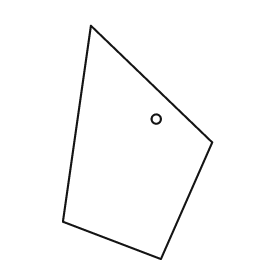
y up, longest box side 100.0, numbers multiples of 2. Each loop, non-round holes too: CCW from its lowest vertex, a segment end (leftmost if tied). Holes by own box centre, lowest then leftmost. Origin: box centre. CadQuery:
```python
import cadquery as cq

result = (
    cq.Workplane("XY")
    .moveTo(10.0, -50.0)
    .lineTo(32.0, 0.0)
    .lineTo(-20.0, 50.0)
    .lineTo(-32.0, -34.0)
    .close()
    .moveTo(8.0, 10.0)
    .circle(2.0)
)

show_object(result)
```